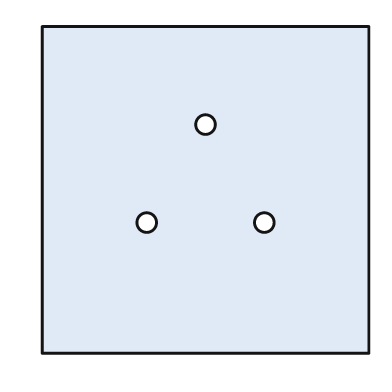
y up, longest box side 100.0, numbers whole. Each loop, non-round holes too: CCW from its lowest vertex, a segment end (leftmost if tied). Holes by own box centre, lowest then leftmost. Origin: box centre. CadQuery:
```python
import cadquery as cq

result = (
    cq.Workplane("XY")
    .moveTo(-50.0, -50.0)
    .lineTo(50.0, -50.0)
    .lineTo(50.0, 50.0)
    .lineTo(-50.0, 50.0)
    .close()
    .moveTo(-18.0, -10.0)
    .circle(3.0)
    .moveTo(18.0, -10.0)
    .circle(3.0)
    .moveTo(0.0, 20.0)
    .circle(3.0)
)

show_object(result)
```